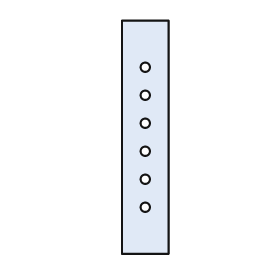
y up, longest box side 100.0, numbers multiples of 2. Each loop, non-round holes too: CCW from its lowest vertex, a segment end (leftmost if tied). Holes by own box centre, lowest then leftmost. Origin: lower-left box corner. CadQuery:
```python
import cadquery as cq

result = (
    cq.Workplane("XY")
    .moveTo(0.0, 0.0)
    .lineTo(20.0, 0.0)
    .lineTo(20.0, 100.0)
    .lineTo(0.0, 100.0)
    .close()
    .moveTo(10.0, 20.0)
    .circle(2.0)
    .moveTo(10.0, 32.0)
    .circle(2.0)
    .moveTo(10.0, 44.0)
    .circle(2.0)
    .moveTo(10.0, 56.0)
    .circle(2.0)
    .moveTo(10.0, 68.0)
    .circle(2.0)
    .moveTo(10.0, 80.0)
    .circle(2.0)
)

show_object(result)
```